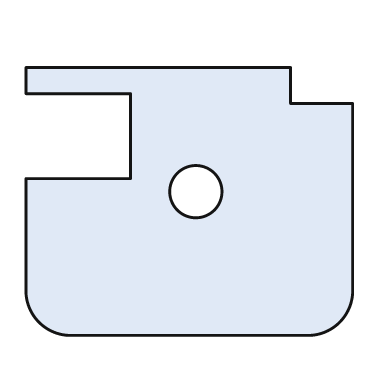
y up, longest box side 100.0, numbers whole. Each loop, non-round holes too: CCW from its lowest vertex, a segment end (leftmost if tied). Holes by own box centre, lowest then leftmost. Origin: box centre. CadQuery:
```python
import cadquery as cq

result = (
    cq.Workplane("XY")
    .moveTo(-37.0, -41.0)
    .lineTo(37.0, -41.0)
    .threePointArc((46.0, -37.0), (50.0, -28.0))
    .lineTo(50.0, 30.0)
    .lineTo(31.0, 30.0)
    .lineTo(31.0, 41.0)
    .lineTo(-50.0, 41.0)
    .lineTo(-50.0, 33.0)
    .lineTo(-18.0, 33.0)
    .lineTo(-18.0, 7.0)
    .lineTo(-50.0, 7.0)
    .lineTo(-50.0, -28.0)
    .threePointArc((-46.0, -37.0), (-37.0, -41.0))
    .close()
    .moveTo(2.0, 3.0)
    .circle(8.0)
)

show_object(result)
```